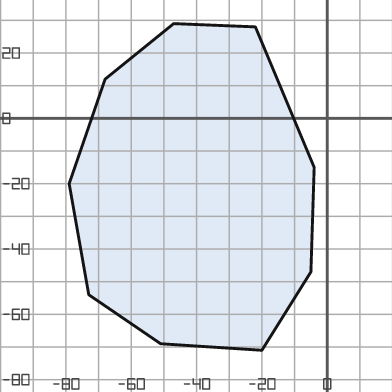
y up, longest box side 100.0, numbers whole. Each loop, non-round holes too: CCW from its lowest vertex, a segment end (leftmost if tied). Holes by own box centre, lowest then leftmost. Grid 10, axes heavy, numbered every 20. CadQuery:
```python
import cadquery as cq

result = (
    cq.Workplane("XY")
    .moveTo(-20.0, -71.0)
    .lineTo(-5.0, -47.0)
    .lineTo(-4.0, -15.0)
    .lineTo(-22.0, 28.0)
    .lineTo(-47.0, 29.0)
    .lineTo(-68.0, 12.0)
    .lineTo(-79.0, -20.0)
    .lineTo(-73.0, -54.0)
    .lineTo(-51.0, -69.0)
    .close()
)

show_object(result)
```